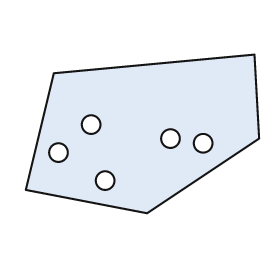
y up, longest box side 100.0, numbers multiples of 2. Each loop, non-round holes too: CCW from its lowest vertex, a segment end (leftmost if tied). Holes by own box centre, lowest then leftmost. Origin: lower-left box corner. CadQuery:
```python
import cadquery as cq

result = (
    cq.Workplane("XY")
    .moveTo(52.0, 0.0)
    .lineTo(100.0, 32.0)
    .lineTo(98.0, 68.0)
    .lineTo(12.0, 60.0)
    .lineTo(0.0, 10.0)
    .close()
    .moveTo(34.0, 14.0)
    .circle(4.0)
    .moveTo(14.0, 26.0)
    .circle(4.0)
    .moveTo(76.0, 30.0)
    .circle(4.0)
    .moveTo(62.0, 32.0)
    .circle(4.0)
    .moveTo(28.0, 38.0)
    .circle(4.0)
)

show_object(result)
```